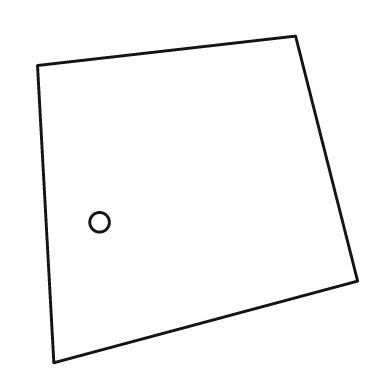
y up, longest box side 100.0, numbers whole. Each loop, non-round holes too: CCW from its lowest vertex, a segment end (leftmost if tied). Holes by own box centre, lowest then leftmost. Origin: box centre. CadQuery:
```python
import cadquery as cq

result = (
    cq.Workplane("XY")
    .moveTo(-44.0, -50.0)
    .lineTo(49.0, -25.0)
    .lineTo(30.0, 50.0)
    .lineTo(-49.0, 41.0)
    .close()
    .moveTo(-30.0, -7.0)
    .circle(3.0)
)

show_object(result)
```